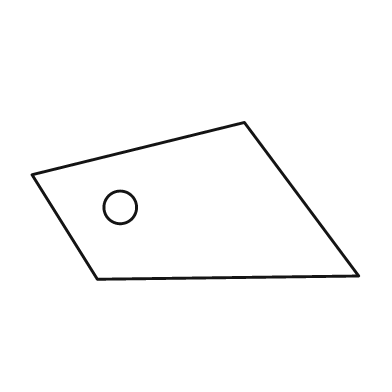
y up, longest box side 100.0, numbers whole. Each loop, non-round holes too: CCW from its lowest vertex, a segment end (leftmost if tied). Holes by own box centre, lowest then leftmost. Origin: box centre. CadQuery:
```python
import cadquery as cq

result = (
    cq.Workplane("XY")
    .moveTo(-30.0, -24.0)
    .lineTo(50.0, -23.0)
    .lineTo(15.0, 24.0)
    .lineTo(-50.0, 8.0)
    .close()
    .moveTo(-23.0, -2.0)
    .circle(5.0)
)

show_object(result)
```